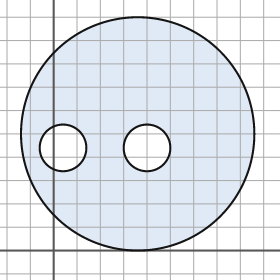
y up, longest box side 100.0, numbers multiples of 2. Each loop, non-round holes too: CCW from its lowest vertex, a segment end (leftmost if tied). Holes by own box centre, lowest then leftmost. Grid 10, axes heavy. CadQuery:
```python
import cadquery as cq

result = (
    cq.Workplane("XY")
    .moveTo(36.0, 50.0)
    .circle(50.0)
    .moveTo(4.0, 44.0)
    .circle(10.0)
    .moveTo(40.0, 44.0)
    .circle(10.0)
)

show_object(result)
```